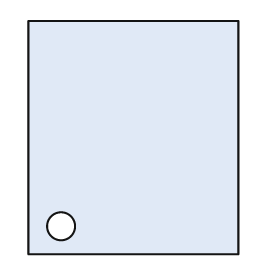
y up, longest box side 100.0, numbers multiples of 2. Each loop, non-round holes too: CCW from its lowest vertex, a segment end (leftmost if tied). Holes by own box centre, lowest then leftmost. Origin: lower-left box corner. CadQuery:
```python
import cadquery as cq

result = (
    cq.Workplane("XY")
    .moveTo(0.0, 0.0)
    .lineTo(90.0, 0.0)
    .lineTo(90.0, 100.0)
    .lineTo(0.0, 100.0)
    .close()
    .moveTo(14.0, 12.0)
    .circle(6.0)
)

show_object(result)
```